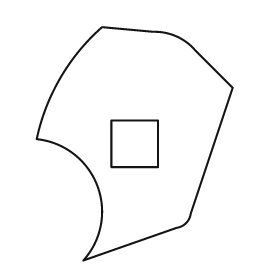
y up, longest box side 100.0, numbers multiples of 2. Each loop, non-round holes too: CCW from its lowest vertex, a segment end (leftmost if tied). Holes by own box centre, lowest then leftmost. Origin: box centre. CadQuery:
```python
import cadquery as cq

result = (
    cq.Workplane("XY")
    .moveTo(-22.0, -50.0)
    .lineTo(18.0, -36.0)
    .threePointArc((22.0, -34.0), (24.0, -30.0))
    .lineTo(42.0, 24.0)
    .lineTo(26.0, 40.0)
    .threePointArc((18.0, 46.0), (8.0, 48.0))
    .lineTo(-14.0, 50.0)
    .threePointArc((-32.0, 28.0), (-42.0, 2.0))
    .threePointArc((-16.0, -18.0), (-22.0, -50.0))
    .close()
    .moveTo(-10.0, -10.0)
    .lineTo(10.0, -10.0)
    .lineTo(10.0, 10.0)
    .lineTo(-10.0, 10.0)
    .close()
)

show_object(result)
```